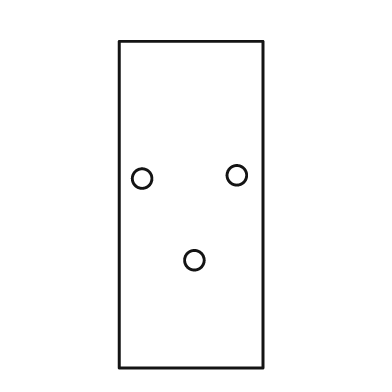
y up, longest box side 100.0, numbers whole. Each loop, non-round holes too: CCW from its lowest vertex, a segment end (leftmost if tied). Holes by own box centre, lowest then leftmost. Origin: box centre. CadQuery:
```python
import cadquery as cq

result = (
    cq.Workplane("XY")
    .moveTo(-22.0, -50.0)
    .lineTo(22.0, -50.0)
    .lineTo(22.0, 50.0)
    .lineTo(-22.0, 50.0)
    .close()
    .moveTo(1.0, -17.0)
    .circle(3.0)
    .moveTo(-15.0, 8.0)
    .circle(3.0)
    .moveTo(14.0, 9.0)
    .circle(3.0)
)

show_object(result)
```